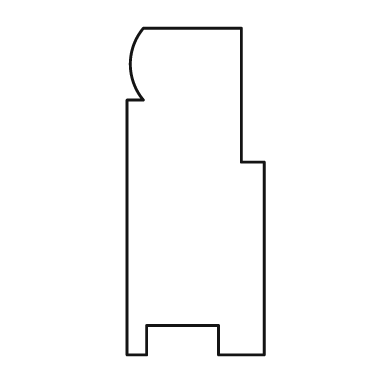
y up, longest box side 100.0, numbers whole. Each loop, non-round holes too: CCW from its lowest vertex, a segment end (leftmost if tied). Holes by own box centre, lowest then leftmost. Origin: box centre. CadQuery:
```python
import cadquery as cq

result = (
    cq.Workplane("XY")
    .moveTo(-21.0, -50.0)
    .lineTo(-15.0, -50.0)
    .lineTo(-15.0, -41.0)
    .lineTo(7.0, -41.0)
    .lineTo(7.0, -50.0)
    .lineTo(21.0, -50.0)
    .lineTo(21.0, 9.0)
    .lineTo(14.0, 9.0)
    .lineTo(14.0, 50.0)
    .lineTo(-16.0, 50.0)
    .threePointArc((-20.0, 39.0), (-16.0, 28.0))
    .lineTo(-21.0, 28.0)
    .close()
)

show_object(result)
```